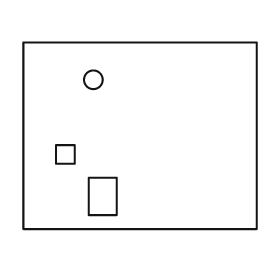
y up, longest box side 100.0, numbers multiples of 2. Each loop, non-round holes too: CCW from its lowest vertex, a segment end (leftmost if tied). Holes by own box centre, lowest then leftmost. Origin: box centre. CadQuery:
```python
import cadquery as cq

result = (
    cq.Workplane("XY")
    .moveTo(-50.0, -40.0)
    .lineTo(50.0, -40.0)
    .lineTo(50.0, 40.0)
    .lineTo(-50.0, 40.0)
    .close()
    .moveTo(-22.0, -34.0)
    .lineTo(-10.0, -34.0)
    .lineTo(-10.0, -18.0)
    .lineTo(-22.0, -18.0)
    .close()
    .moveTo(-36.0, -12.0)
    .lineTo(-28.0, -12.0)
    .lineTo(-28.0, -4.0)
    .lineTo(-36.0, -4.0)
    .close()
    .moveTo(-20.0, 24.0)
    .circle(4.0)
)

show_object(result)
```